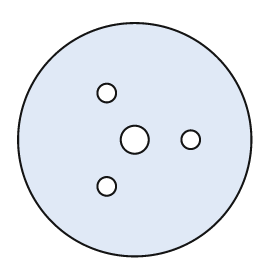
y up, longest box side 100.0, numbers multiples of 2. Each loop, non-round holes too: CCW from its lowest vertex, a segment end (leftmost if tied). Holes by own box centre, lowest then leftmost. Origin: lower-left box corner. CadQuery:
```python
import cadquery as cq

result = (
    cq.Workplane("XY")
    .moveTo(50.0, 50.0)
    .circle(50.0)
    .moveTo(38.0, 30.0)
    .circle(4.0)
    .moveTo(50.0, 50.0)
    .circle(6.0)
    .moveTo(74.0, 50.0)
    .circle(4.0)
    .moveTo(38.0, 70.0)
    .circle(4.0)
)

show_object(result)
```